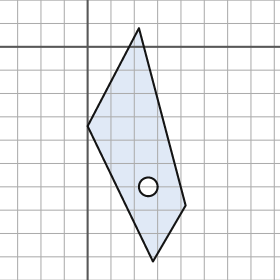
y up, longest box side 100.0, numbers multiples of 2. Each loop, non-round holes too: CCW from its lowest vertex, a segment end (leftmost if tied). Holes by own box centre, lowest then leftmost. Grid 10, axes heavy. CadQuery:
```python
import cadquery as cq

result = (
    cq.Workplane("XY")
    .moveTo(28.0, -92.0)
    .lineTo(42.0, -68.0)
    .lineTo(22.0, 8.0)
    .lineTo(0.0, -34.0)
    .close()
    .moveTo(26.0, -60.0)
    .circle(4.0)
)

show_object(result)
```